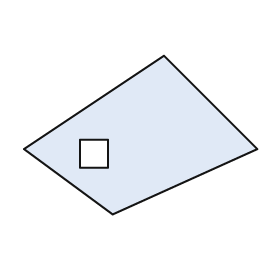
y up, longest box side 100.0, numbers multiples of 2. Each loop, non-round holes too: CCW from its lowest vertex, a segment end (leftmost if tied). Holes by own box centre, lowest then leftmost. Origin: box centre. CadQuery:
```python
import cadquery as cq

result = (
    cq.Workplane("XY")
    .moveTo(-12.0, -34.0)
    .lineTo(50.0, -6.0)
    .lineTo(10.0, 34.0)
    .lineTo(-50.0, -6.0)
    .close()
    .moveTo(-26.0, -14.0)
    .lineTo(-14.0, -14.0)
    .lineTo(-14.0, -2.0)
    .lineTo(-26.0, -2.0)
    .close()
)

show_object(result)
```